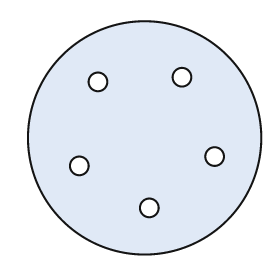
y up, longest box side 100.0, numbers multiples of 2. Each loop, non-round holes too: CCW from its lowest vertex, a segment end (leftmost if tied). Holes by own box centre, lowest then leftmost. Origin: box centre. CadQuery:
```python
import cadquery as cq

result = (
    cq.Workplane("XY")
    .moveTo(0.0, 0.0)
    .circle(50.0)
    .moveTo(2.0, -30.0)
    .circle(4.0)
    .moveTo(-28.0, -12.0)
    .circle(4.0)
    .moveTo(30.0, -8.0)
    .circle(4.0)
    .moveTo(-20.0, 24.0)
    .circle(4.0)
    .moveTo(16.0, 26.0)
    .circle(4.0)
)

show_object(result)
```